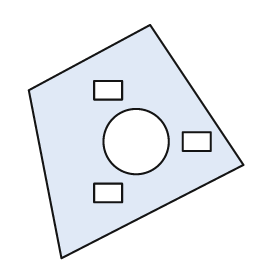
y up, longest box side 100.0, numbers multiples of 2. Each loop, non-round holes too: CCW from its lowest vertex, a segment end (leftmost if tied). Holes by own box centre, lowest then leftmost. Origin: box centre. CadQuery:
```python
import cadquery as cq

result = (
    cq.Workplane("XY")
    .moveTo(-32.0, -50.0)
    .lineTo(46.0, -10.0)
    .lineTo(6.0, 50.0)
    .lineTo(-46.0, 22.0)
    .close()
    .moveTo(-18.0, -26.0)
    .lineTo(-6.0, -26.0)
    .lineTo(-6.0, -18.0)
    .lineTo(-18.0, -18.0)
    .close()
    .moveTo(0.0, 0.0)
    .circle(14.0)
    .moveTo(20.0, -4.0)
    .lineTo(32.0, -4.0)
    .lineTo(32.0, 4.0)
    .lineTo(20.0, 4.0)
    .close()
    .moveTo(-18.0, 18.0)
    .lineTo(-6.0, 18.0)
    .lineTo(-6.0, 26.0)
    .lineTo(-18.0, 26.0)
    .close()
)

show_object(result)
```